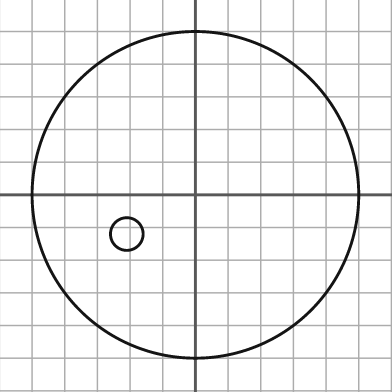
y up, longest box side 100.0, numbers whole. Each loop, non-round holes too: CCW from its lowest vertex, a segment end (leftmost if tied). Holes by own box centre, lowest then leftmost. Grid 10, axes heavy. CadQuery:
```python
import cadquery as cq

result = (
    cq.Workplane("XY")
    .moveTo(0.0, 0.0)
    .circle(50.0)
    .moveTo(-21.0, -12.0)
    .circle(5.0)
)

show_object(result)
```